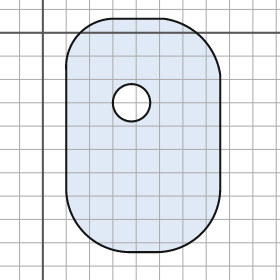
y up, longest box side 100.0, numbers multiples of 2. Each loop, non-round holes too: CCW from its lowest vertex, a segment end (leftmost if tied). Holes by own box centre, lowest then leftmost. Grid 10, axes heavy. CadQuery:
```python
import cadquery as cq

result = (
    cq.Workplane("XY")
    .moveTo(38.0, -94.0)
    .lineTo(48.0, -94.0)
    .threePointArc((68.0, -86.0), (76.0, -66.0))
    .lineTo(76.0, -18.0)
    .threePointArc((68.0, -2.0), (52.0, 6.0))
    .lineTo(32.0, 6.0)
    .threePointArc((16.0, 0.0), (10.0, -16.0))
    .lineTo(10.0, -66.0)
    .threePointArc((18.0, -86.0), (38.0, -94.0))
    .close()
    .moveTo(38.0, -30.0)
    .circle(8.0)
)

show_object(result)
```